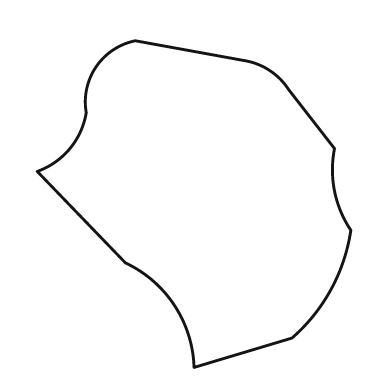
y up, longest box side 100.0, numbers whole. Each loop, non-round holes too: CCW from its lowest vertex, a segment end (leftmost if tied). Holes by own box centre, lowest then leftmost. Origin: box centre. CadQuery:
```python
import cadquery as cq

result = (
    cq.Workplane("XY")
    .moveTo(0.0, -50.0)
    .lineTo(30.0, -41.0)
    .threePointArc((42.0, -26.0), (48.0, -8.0))
    .threePointArc((43.0, 4.0), (43.0, 17.0))
    .lineTo(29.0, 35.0)
    .threePointArc((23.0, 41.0), (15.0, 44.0))
    .lineTo(-18.0, 50.0)
    .threePointArc((-30.0, 42.0), (-33.0, 28.0))
    .threePointArc((-38.0, 17.0), (-48.0, 10.0))
    .lineTo(-21.0, -18.0)
    .threePointArc((-6.0, -31.0), (0.0, -50.0))
    .close()
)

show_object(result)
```